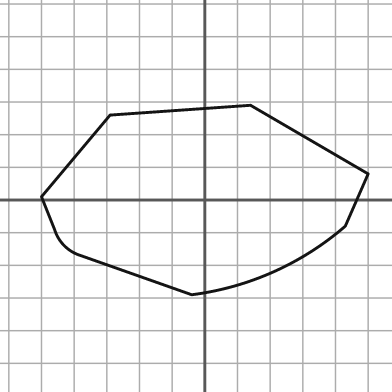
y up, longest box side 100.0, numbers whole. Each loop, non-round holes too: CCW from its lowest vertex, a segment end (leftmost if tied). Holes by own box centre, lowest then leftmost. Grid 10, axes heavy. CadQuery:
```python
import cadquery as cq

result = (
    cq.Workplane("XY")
    .moveTo(-4.0, -29.0)
    .threePointArc((21.0, -22.0), (43.0, -8.0))
    .lineTo(50.0, 8.0)
    .lineTo(14.0, 29.0)
    .lineTo(-29.0, 26.0)
    .lineTo(-50.0, 1.0)
    .lineTo(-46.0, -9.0)
    .threePointArc((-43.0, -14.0), (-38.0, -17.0))
    .close()
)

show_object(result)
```